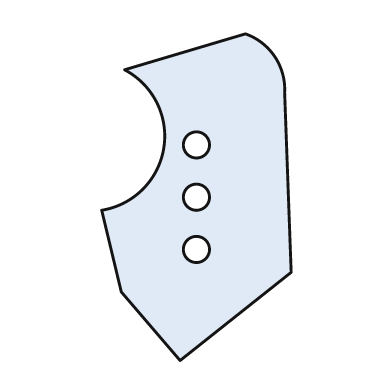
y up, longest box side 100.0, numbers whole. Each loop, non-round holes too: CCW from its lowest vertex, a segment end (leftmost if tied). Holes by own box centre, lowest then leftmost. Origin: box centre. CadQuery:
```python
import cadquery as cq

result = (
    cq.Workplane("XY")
    .moveTo(-5.0, -50.0)
    .lineTo(29.0, -23.0)
    .lineTo(27.0, 32.0)
    .threePointArc((24.0, 43.0), (15.0, 50.0))
    .lineTo(-22.0, 39.0)
    .threePointArc((-10.0, 15.0), (-29.0, -4.0))
    .lineTo(-23.0, -29.0)
    .close()
    .moveTo(0.0, -16.0)
    .circle(4.0)
    .moveTo(0.0, 0.0)
    .circle(4.0)
    .moveTo(0.0, 16.0)
    .circle(4.0)
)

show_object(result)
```